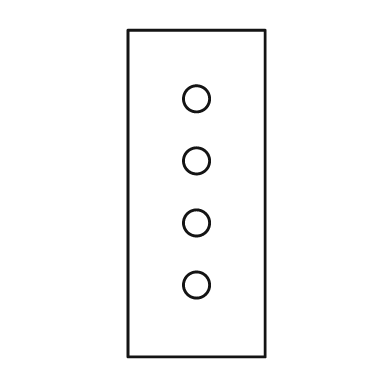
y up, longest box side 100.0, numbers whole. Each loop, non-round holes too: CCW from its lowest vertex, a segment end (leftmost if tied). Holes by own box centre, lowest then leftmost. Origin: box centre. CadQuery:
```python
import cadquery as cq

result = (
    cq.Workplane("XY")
    .moveTo(-21.0, -50.0)
    .lineTo(21.0, -50.0)
    .lineTo(21.0, 50.0)
    .lineTo(-21.0, 50.0)
    .close()
    .moveTo(0.0, -28.0)
    .circle(4.0)
    .moveTo(0.0, -9.0)
    .circle(4.0)
    .moveTo(0.0, 10.0)
    .circle(4.0)
    .moveTo(0.0, 29.0)
    .circle(4.0)
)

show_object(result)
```